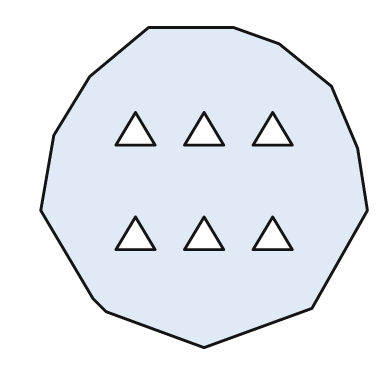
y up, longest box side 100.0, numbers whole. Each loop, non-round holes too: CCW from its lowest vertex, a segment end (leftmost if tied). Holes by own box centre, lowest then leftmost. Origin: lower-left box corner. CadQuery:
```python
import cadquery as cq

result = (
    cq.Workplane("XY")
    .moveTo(50.0, 0.0)
    .lineTo(83.0, 12.0)
    .lineTo(100.0, 42.0)
    .lineTo(97.0, 61.0)
    .lineTo(89.0, 80.0)
    .lineTo(73.0, 93.0)
    .lineTo(59.0, 98.0)
    .lineTo(33.0, 98.0)
    .lineTo(15.0, 83.0)
    .lineTo(4.0, 65.0)
    .lineTo(0.0, 42.0)
    .lineTo(16.0, 15.0)
    .lineTo(20.0, 11.0)
    .close()
    .moveTo(23.0, 30.0)
    .lineTo(35.0, 30.0)
    .lineTo(29.0, 40.0)
    .close()
    .moveTo(44.0, 30.0)
    .lineTo(56.0, 30.0)
    .lineTo(50.0, 40.0)
    .close()
    .moveTo(65.0, 30.0)
    .lineTo(77.0, 30.0)
    .lineTo(71.0, 40.0)
    .close()
    .moveTo(23.0, 62.0)
    .lineTo(35.0, 62.0)
    .lineTo(29.0, 72.0)
    .close()
    .moveTo(44.0, 62.0)
    .lineTo(56.0, 62.0)
    .lineTo(50.0, 72.0)
    .close()
    .moveTo(65.0, 62.0)
    .lineTo(77.0, 62.0)
    .lineTo(71.0, 72.0)
    .close()
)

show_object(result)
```